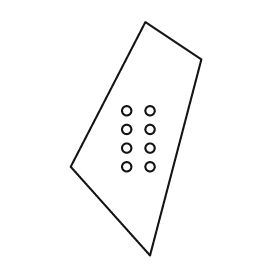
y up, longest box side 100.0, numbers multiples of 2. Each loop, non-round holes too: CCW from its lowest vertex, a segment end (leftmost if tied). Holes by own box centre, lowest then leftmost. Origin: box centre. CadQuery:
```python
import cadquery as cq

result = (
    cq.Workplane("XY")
    .moveTo(6.0, -50.0)
    .lineTo(28.0, 34.0)
    .lineTo(4.0, 50.0)
    .lineTo(-28.0, -12.0)
    .close()
    .moveTo(-4.0, -12.0)
    .circle(2.0)
    .moveTo(6.0, -12.0)
    .circle(2.0)
    .moveTo(-4.0, -4.0)
    .circle(2.0)
    .moveTo(6.0, -4.0)
    .circle(2.0)
    .moveTo(-4.0, 4.0)
    .circle(2.0)
    .moveTo(6.0, 4.0)
    .circle(2.0)
    .moveTo(-4.0, 12.0)
    .circle(2.0)
    .moveTo(6.0, 12.0)
    .circle(2.0)
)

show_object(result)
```